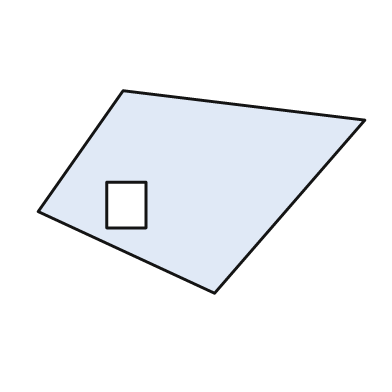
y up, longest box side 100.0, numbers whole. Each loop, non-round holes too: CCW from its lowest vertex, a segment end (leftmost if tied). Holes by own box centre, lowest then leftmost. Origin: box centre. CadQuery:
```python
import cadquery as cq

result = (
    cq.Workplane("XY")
    .moveTo(4.0, -31.0)
    .lineTo(50.0, 22.0)
    .lineTo(-24.0, 31.0)
    .lineTo(-50.0, -6.0)
    .close()
    .moveTo(-29.0, -11.0)
    .lineTo(-17.0, -11.0)
    .lineTo(-17.0, 3.0)
    .lineTo(-29.0, 3.0)
    .close()
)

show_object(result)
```